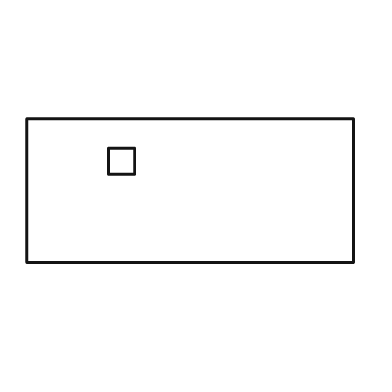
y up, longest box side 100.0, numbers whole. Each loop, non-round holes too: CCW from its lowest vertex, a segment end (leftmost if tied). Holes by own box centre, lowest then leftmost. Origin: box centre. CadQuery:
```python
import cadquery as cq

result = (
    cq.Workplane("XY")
    .moveTo(-50.0, -22.0)
    .lineTo(50.0, -22.0)
    .lineTo(50.0, 22.0)
    .lineTo(-50.0, 22.0)
    .close()
    .moveTo(-25.0, 5.0)
    .lineTo(-17.0, 5.0)
    .lineTo(-17.0, 13.0)
    .lineTo(-25.0, 13.0)
    .close()
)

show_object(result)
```